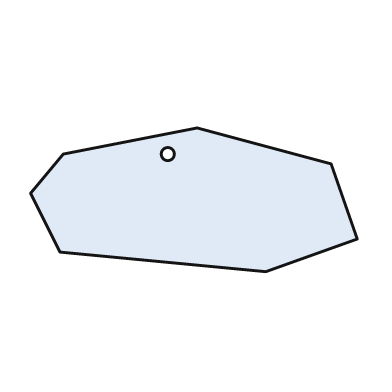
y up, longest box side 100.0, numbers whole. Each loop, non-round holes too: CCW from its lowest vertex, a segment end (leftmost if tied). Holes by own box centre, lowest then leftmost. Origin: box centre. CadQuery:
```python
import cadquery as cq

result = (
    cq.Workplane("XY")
    .moveTo(22.0, -22.0)
    .lineTo(50.0, -12.0)
    .lineTo(42.0, 11.0)
    .lineTo(1.0, 22.0)
    .lineTo(-40.0, 14.0)
    .lineTo(-50.0, 2.0)
    .lineTo(-41.0, -16.0)
    .close()
    .moveTo(-8.0, 14.0)
    .circle(2.0)
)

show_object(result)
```